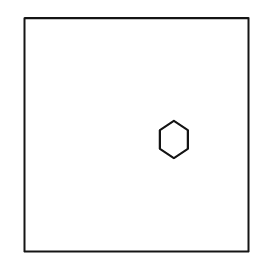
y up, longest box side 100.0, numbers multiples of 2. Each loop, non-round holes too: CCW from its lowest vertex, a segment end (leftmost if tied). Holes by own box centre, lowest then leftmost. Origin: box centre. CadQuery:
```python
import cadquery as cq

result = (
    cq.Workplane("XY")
    .moveTo(-48.0, -50.0)
    .lineTo(48.0, -50.0)
    .lineTo(48.0, 50.0)
    .lineTo(-48.0, 50.0)
    .close()
    .moveTo(16.0, -10.0)
    .lineTo(22.0, -6.0)
    .lineTo(22.0, 2.0)
    .lineTo(16.0, 6.0)
    .lineTo(10.0, 2.0)
    .lineTo(10.0, -6.0)
    .close()
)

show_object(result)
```